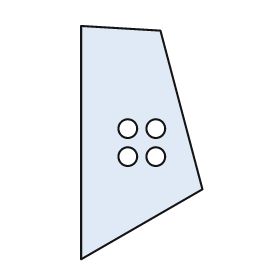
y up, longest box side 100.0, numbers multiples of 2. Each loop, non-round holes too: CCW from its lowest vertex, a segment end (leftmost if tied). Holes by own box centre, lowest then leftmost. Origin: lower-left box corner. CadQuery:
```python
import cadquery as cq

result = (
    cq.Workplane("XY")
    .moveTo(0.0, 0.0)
    .lineTo(52.0, 30.0)
    .lineTo(34.0, 98.0)
    .lineTo(0.0, 100.0)
    .close()
    .moveTo(20.0, 44.0)
    .circle(4.0)
    .moveTo(32.0, 44.0)
    .circle(4.0)
    .moveTo(20.0, 56.0)
    .circle(4.0)
    .moveTo(32.0, 56.0)
    .circle(4.0)
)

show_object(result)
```